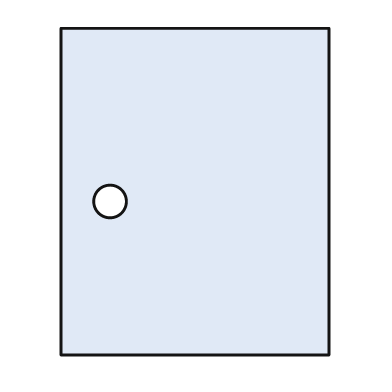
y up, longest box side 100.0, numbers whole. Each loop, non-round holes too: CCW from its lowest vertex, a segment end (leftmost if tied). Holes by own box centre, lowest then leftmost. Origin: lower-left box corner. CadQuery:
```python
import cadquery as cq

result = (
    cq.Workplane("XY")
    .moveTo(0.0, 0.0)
    .lineTo(82.0, 0.0)
    .lineTo(82.0, 100.0)
    .lineTo(0.0, 100.0)
    .close()
    .moveTo(15.0, 47.0)
    .circle(5.0)
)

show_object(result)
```